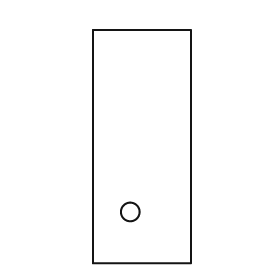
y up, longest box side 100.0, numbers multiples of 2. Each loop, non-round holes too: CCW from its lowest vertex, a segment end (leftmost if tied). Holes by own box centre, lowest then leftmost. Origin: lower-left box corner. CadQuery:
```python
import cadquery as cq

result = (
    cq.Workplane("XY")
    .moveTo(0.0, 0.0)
    .lineTo(42.0, 0.0)
    .lineTo(42.0, 100.0)
    .lineTo(0.0, 100.0)
    .close()
    .moveTo(16.0, 22.0)
    .circle(4.0)
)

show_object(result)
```